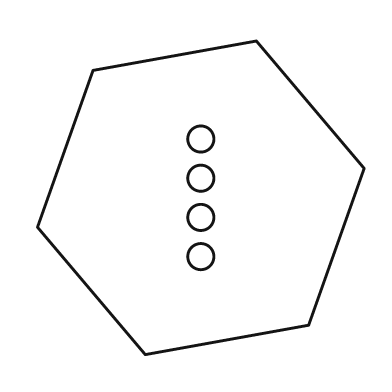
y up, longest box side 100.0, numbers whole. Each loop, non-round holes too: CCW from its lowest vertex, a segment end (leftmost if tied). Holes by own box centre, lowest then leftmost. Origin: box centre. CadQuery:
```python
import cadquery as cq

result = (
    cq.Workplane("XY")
    .moveTo(-17.0, -48.0)
    .lineTo(33.0, -39.0)
    .lineTo(50.0, 9.0)
    .lineTo(17.0, 48.0)
    .lineTo(-33.0, 39.0)
    .lineTo(-50.0, -9.0)
    .close()
    .moveTo(0.0, -18.0)
    .circle(4.0)
    .moveTo(0.0, -6.0)
    .circle(4.0)
    .moveTo(0.0, 6.0)
    .circle(4.0)
    .moveTo(0.0, 18.0)
    .circle(4.0)
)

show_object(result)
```